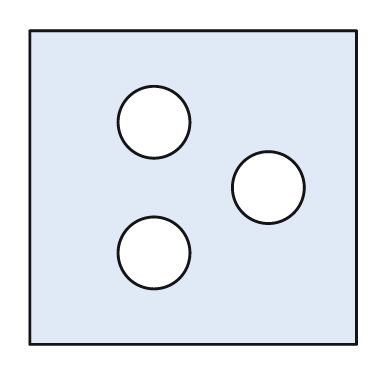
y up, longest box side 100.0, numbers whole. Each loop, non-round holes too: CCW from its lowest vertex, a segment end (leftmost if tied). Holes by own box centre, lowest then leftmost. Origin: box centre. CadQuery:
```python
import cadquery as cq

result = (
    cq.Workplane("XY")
    .moveTo(-50.0, -48.0)
    .lineTo(50.0, -48.0)
    .lineTo(50.0, 48.0)
    .lineTo(-50.0, 48.0)
    .close()
    .moveTo(-12.0, -20.0)
    .circle(11.0)
    .moveTo(23.0, 0.0)
    .circle(11.0)
    .moveTo(-12.0, 20.0)
    .circle(11.0)
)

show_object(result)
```